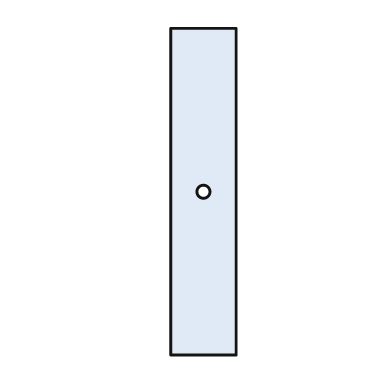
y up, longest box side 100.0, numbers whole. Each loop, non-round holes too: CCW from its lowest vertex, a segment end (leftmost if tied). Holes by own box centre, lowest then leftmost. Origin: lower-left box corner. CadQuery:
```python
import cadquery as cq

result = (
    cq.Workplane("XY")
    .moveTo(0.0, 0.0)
    .lineTo(20.0, 0.0)
    .lineTo(20.0, 100.0)
    .lineTo(0.0, 100.0)
    .close()
    .moveTo(10.0, 50.0)
    .circle(2.0)
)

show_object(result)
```